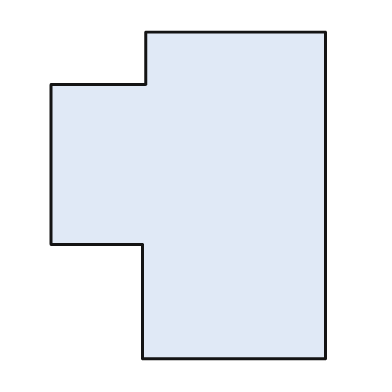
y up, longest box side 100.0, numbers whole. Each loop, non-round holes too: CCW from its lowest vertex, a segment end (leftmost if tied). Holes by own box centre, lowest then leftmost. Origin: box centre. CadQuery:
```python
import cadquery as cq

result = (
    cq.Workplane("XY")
    .moveTo(-14.0, -50.0)
    .lineTo(42.0, -50.0)
    .lineTo(42.0, 50.0)
    .lineTo(-13.0, 50.0)
    .lineTo(-13.0, 34.0)
    .lineTo(-42.0, 34.0)
    .lineTo(-42.0, -15.0)
    .lineTo(-14.0, -15.0)
    .close()
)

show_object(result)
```